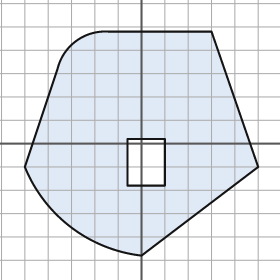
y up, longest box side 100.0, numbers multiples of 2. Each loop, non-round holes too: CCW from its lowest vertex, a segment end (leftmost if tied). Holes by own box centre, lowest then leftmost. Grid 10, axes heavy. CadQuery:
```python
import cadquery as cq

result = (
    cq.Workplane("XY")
    .moveTo(0.0, -48.0)
    .lineTo(50.0, -10.0)
    .lineTo(30.0, 48.0)
    .lineTo(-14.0, 48.0)
    .threePointArc((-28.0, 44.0), (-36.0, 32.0))
    .lineTo(-50.0, -10.0)
    .threePointArc((-30.0, -36.0), (0.0, -48.0))
    .close()
    .moveTo(-6.0, -18.0)
    .lineTo(10.0, -18.0)
    .lineTo(10.0, 2.0)
    .lineTo(-6.0, 2.0)
    .close()
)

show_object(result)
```